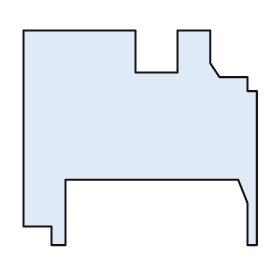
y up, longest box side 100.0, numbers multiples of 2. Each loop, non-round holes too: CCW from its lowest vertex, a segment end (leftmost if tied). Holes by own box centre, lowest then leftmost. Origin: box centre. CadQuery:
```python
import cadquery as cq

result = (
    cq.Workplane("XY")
    .moveTo(-38.0, -46.0)
    .lineTo(-32.0, -46.0)
    .lineTo(-32.0, -18.0)
    .lineTo(42.0, -18.0)
    .lineTo(46.0, -28.0)
    .lineTo(46.0, -46.0)
    .lineTo(50.0, -46.0)
    .lineTo(50.0, 20.0)
    .lineTo(46.0, 20.0)
    .lineTo(46.0, 26.0)
    .lineTo(34.0, 26.0)
    .lineTo(30.0, 32.0)
    .lineTo(30.0, 46.0)
    .lineTo(16.0, 46.0)
    .lineTo(16.0, 28.0)
    .lineTo(-2.0, 28.0)
    .lineTo(-2.0, 46.0)
    .lineTo(-50.0, 46.0)
    .lineTo(-50.0, -38.0)
    .lineTo(-38.0, -38.0)
    .close()
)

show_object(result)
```